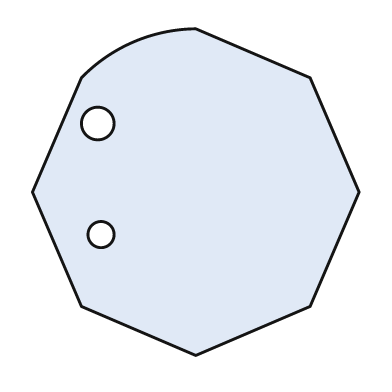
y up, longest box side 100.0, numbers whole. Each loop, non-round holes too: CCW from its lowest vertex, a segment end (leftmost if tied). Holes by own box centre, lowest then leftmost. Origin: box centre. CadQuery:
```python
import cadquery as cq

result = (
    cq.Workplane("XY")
    .moveTo(0.0, -50.0)
    .lineTo(35.0, -35.0)
    .lineTo(50.0, 0.0)
    .lineTo(35.0, 35.0)
    .lineTo(0.0, 50.0)
    .threePointArc((-19.0, 46.0), (-35.0, 35.0))
    .lineTo(-50.0, 0.0)
    .lineTo(-35.0, -35.0)
    .close()
    .moveTo(-29.0, -13.0)
    .circle(4.0)
    .moveTo(-30.0, 21.0)
    .circle(5.0)
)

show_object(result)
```